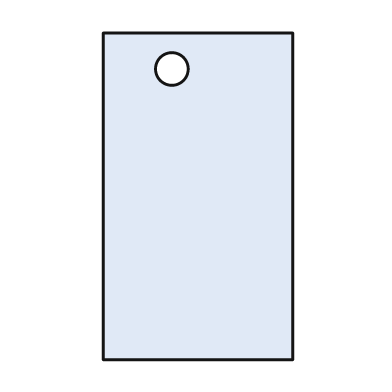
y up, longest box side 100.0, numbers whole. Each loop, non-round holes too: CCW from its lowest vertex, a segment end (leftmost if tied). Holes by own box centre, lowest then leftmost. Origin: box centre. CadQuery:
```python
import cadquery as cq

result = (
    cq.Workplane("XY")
    .moveTo(-29.0, -50.0)
    .lineTo(29.0, -50.0)
    .lineTo(29.0, 50.0)
    .lineTo(-29.0, 50.0)
    .close()
    .moveTo(-8.0, 39.0)
    .circle(5.0)
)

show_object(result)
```